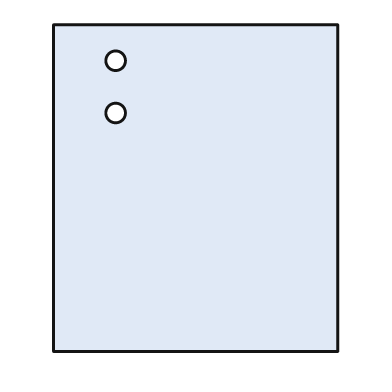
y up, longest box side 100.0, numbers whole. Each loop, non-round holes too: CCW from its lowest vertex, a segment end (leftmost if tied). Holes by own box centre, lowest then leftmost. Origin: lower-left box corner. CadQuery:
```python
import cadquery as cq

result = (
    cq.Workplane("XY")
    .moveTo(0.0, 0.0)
    .lineTo(87.0, 0.0)
    .lineTo(87.0, 100.0)
    .lineTo(0.0, 100.0)
    .close()
    .moveTo(19.0, 73.0)
    .circle(3.0)
    .moveTo(19.0, 89.0)
    .circle(3.0)
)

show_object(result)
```